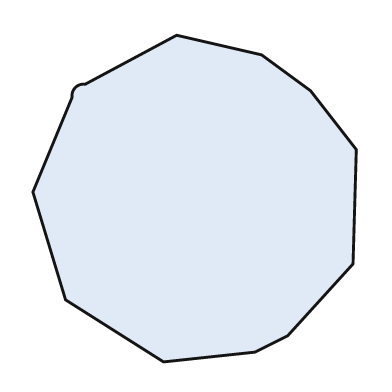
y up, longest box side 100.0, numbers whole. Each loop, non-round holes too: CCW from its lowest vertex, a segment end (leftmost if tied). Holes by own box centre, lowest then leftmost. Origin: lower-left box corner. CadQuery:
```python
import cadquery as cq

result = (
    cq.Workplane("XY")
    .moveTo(40.0, 0.0)
    .lineTo(68.0, 3.0)
    .lineTo(78.0, 8.0)
    .lineTo(98.0, 30.0)
    .lineTo(99.0, 65.0)
    .lineTo(85.0, 83.0)
    .lineTo(70.0, 94.0)
    .lineTo(44.0, 100.0)
    .lineTo(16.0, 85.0)
    .threePointArc((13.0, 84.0), (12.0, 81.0))
    .lineTo(0.0, 52.0)
    .lineTo(10.0, 19.0)
    .close()
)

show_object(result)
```